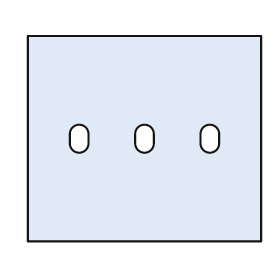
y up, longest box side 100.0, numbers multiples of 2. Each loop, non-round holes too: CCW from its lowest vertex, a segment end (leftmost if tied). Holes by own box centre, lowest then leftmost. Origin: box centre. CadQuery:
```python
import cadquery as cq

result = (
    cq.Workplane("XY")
    .moveTo(-50.0, -44.0)
    .lineTo(50.0, -44.0)
    .lineTo(50.0, 44.0)
    .lineTo(-50.0, 44.0)
    .close()
    .moveTo(-32.0, -2.0)
    .threePointArc((-28.0, -6.0), (-24.0, -2.0))
    .lineTo(-24.0, 2.0)
    .threePointArc((-28.0, 6.0), (-32.0, 2.0))
    .close()
    .moveTo(-4.0, -2.0)
    .threePointArc((0.0, -6.0), (4.0, -2.0))
    .lineTo(4.0, 2.0)
    .threePointArc((0.0, 6.0), (-4.0, 2.0))
    .close()
    .moveTo(24.0, -2.0)
    .threePointArc((28.0, -6.0), (32.0, -2.0))
    .lineTo(32.0, 2.0)
    .threePointArc((28.0, 6.0), (24.0, 2.0))
    .close()
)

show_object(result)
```